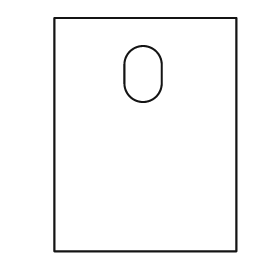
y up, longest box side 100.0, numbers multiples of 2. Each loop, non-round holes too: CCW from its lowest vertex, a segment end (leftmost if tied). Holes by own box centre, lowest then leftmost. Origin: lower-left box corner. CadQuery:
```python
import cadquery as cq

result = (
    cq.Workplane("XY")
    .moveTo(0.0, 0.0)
    .lineTo(78.0, 0.0)
    .lineTo(78.0, 100.0)
    .lineTo(0.0, 100.0)
    .close()
    .moveTo(30.0, 72.0)
    .threePointArc((38.0, 64.0), (46.0, 72.0))
    .lineTo(46.0, 80.0)
    .threePointArc((38.0, 88.0), (30.0, 80.0))
    .close()
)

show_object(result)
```